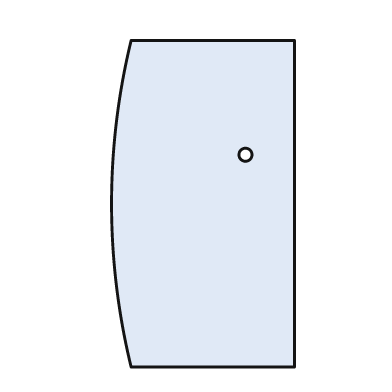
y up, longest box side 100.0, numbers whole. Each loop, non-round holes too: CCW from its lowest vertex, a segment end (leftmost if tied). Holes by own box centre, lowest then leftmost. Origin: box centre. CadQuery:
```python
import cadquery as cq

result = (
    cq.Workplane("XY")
    .moveTo(-22.0, -50.0)
    .lineTo(28.0, -50.0)
    .lineTo(28.0, 50.0)
    .lineTo(-22.0, 50.0)
    .threePointArc((-28.0, 0.0), (-22.0, -50.0))
    .close()
    .moveTo(13.0, 15.0)
    .circle(2.0)
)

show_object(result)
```